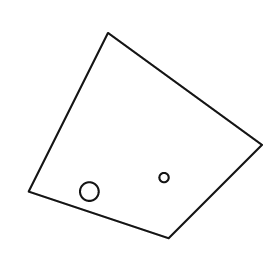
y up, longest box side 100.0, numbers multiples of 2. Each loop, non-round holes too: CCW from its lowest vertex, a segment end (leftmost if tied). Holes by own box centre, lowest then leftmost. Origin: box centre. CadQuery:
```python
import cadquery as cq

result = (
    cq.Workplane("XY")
    .moveTo(10.0, -44.0)
    .lineTo(50.0, -4.0)
    .lineTo(-16.0, 44.0)
    .lineTo(-50.0, -24.0)
    .close()
    .moveTo(-24.0, -24.0)
    .circle(4.0)
    .moveTo(8.0, -18.0)
    .circle(2.0)
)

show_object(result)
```